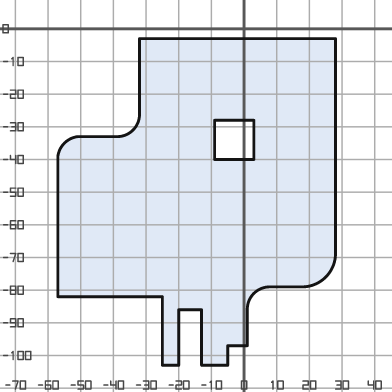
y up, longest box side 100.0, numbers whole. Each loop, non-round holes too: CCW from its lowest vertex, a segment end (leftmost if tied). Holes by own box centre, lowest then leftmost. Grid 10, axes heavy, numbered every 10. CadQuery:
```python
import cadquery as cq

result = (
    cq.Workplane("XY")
    .moveTo(-25.0, -103.0)
    .lineTo(-20.0, -103.0)
    .lineTo(-20.0, -86.0)
    .lineTo(-13.0, -86.0)
    .lineTo(-13.0, -103.0)
    .lineTo(-5.0, -103.0)
    .lineTo(-5.0, -97.0)
    .lineTo(1.0, -97.0)
    .lineTo(1.0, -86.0)
    .threePointArc((3.0, -81.0), (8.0, -79.0))
    .lineTo(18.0, -79.0)
    .threePointArc((25.0, -76.0), (28.0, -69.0))
    .lineTo(28.0, -3.0)
    .lineTo(-32.0, -3.0)
    .lineTo(-32.0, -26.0)
    .threePointArc((-34.0, -31.0), (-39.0, -33.0))
    .lineTo(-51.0, -33.0)
    .threePointArc((-55.0, -35.0), (-57.0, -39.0))
    .lineTo(-57.0, -82.0)
    .lineTo(-25.0, -82.0)
    .close()
    .moveTo(-9.0, -40.0)
    .lineTo(3.0, -40.0)
    .lineTo(3.0, -28.0)
    .lineTo(-9.0, -28.0)
    .close()
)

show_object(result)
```